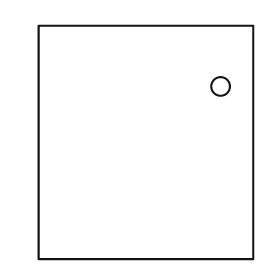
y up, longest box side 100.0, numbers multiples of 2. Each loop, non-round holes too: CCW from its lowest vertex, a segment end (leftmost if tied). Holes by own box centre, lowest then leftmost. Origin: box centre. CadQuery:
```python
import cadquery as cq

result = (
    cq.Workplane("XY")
    .moveTo(-46.0, -50.0)
    .lineTo(46.0, -50.0)
    .lineTo(46.0, 50.0)
    .lineTo(-46.0, 50.0)
    .close()
    .moveTo(32.0, 24.0)
    .circle(4.0)
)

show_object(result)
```